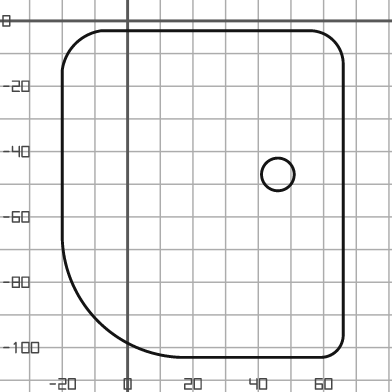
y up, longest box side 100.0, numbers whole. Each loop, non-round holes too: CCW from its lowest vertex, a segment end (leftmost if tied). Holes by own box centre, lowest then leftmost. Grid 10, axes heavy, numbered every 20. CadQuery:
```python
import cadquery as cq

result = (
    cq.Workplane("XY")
    .moveTo(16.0, -103.0)
    .lineTo(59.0, -103.0)
    .threePointArc((64.0, -101.0), (66.0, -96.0))
    .lineTo(66.0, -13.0)
    .threePointArc((63.0, -6.0), (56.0, -3.0))
    .lineTo(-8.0, -3.0)
    .threePointArc((-16.0, -7.0), (-20.0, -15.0))
    .lineTo(-20.0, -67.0)
    .threePointArc((-9.0, -92.0), (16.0, -103.0))
    .close()
    .moveTo(46.0, -47.0)
    .circle(5.0)
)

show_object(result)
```